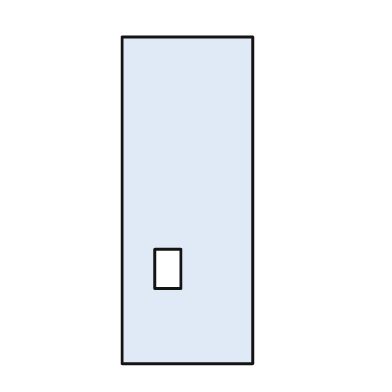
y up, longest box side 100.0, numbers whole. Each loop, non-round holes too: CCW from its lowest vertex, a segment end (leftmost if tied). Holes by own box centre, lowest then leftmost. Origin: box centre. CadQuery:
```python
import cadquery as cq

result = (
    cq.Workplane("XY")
    .moveTo(-20.0, -50.0)
    .lineTo(20.0, -50.0)
    .lineTo(20.0, 50.0)
    .lineTo(-20.0, 50.0)
    .close()
    .moveTo(-10.0, -27.0)
    .lineTo(-2.0, -27.0)
    .lineTo(-2.0, -15.0)
    .lineTo(-10.0, -15.0)
    .close()
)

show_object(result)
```